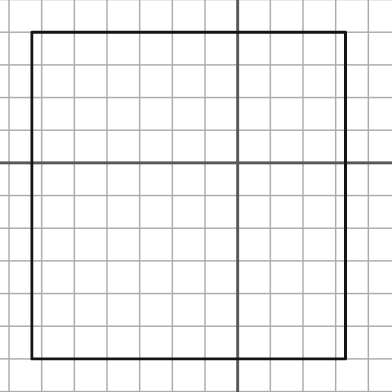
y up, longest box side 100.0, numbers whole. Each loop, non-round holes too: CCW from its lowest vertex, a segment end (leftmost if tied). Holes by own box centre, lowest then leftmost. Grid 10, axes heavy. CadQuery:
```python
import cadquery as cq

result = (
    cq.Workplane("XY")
    .moveTo(-63.0, -60.0)
    .lineTo(33.0, -60.0)
    .lineTo(33.0, 40.0)
    .lineTo(-63.0, 40.0)
    .close()
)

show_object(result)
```